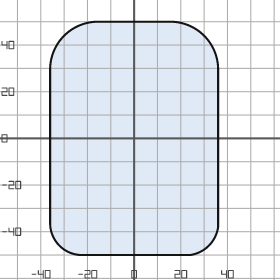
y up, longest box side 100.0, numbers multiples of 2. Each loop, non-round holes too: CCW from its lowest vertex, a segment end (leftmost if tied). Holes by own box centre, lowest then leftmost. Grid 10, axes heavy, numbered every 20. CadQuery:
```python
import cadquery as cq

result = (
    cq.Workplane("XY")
    .moveTo(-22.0, -50.0)
    .lineTo(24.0, -50.0)
    .threePointArc((32.0, -46.0), (36.0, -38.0))
    .lineTo(36.0, 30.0)
    .threePointArc((30.0, 44.0), (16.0, 50.0))
    .lineTo(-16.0, 50.0)
    .threePointArc((-30.0, 44.0), (-36.0, 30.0))
    .lineTo(-36.0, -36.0)
    .threePointArc((-32.0, -46.0), (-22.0, -50.0))
    .close()
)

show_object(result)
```